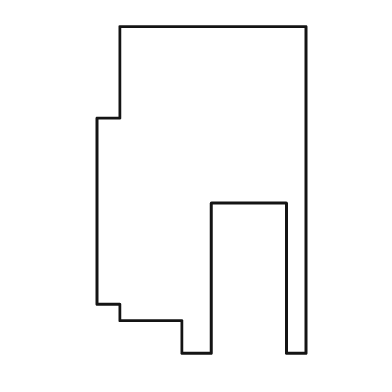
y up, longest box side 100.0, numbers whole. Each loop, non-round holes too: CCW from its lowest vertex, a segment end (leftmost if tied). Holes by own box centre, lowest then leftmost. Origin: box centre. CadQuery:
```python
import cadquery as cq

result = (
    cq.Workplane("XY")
    .moveTo(-6.0, -50.0)
    .lineTo(3.0, -50.0)
    .lineTo(3.0, -4.0)
    .lineTo(26.0, -4.0)
    .lineTo(26.0, -50.0)
    .lineTo(32.0, -50.0)
    .lineTo(32.0, 50.0)
    .lineTo(-25.0, 50.0)
    .lineTo(-25.0, 22.0)
    .lineTo(-32.0, 22.0)
    .lineTo(-32.0, -35.0)
    .lineTo(-25.0, -35.0)
    .lineTo(-25.0, -40.0)
    .lineTo(-6.0, -40.0)
    .close()
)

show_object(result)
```